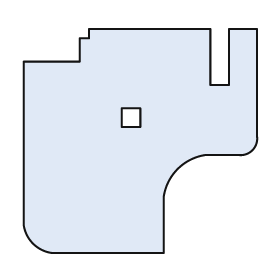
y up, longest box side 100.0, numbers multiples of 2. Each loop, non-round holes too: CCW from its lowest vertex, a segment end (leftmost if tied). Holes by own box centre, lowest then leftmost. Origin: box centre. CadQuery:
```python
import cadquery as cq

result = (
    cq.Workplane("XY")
    .moveTo(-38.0, -48.0)
    .lineTo(10.0, -48.0)
    .lineTo(10.0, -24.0)
    .threePointArc((16.0, -12.0), (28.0, -6.0))
    .lineTo(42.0, -6.0)
    .threePointArc((48.0, -4.0), (50.0, 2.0))
    .lineTo(50.0, 48.0)
    .lineTo(38.0, 48.0)
    .lineTo(38.0, 24.0)
    .lineTo(30.0, 24.0)
    .lineTo(30.0, 48.0)
    .lineTo(-22.0, 48.0)
    .lineTo(-22.0, 44.0)
    .lineTo(-26.0, 44.0)
    .lineTo(-26.0, 34.0)
    .lineTo(-50.0, 34.0)
    .lineTo(-50.0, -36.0)
    .threePointArc((-46.0, -44.0), (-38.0, -48.0))
    .close()
    .moveTo(-8.0, 6.0)
    .lineTo(0.0, 6.0)
    .lineTo(0.0, 14.0)
    .lineTo(-8.0, 14.0)
    .close()
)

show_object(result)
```